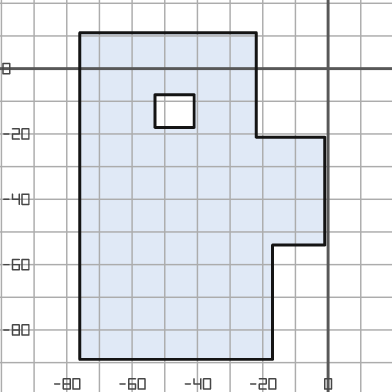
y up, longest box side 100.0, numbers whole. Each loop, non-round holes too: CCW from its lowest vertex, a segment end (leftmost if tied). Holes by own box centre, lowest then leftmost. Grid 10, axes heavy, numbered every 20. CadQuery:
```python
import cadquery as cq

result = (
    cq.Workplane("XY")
    .moveTo(-76.0, -89.0)
    .lineTo(-17.0, -89.0)
    .lineTo(-17.0, -54.0)
    .lineTo(-1.0, -54.0)
    .lineTo(-1.0, -21.0)
    .lineTo(-22.0, -21.0)
    .lineTo(-22.0, 11.0)
    .lineTo(-76.0, 11.0)
    .close()
    .moveTo(-53.0, -18.0)
    .lineTo(-41.0, -18.0)
    .lineTo(-41.0, -8.0)
    .lineTo(-53.0, -8.0)
    .close()
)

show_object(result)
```